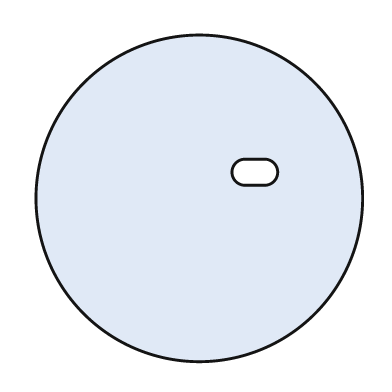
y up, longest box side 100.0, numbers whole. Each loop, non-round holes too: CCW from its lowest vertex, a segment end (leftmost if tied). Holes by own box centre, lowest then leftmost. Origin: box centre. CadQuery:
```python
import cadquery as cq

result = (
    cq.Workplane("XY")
    .moveTo(0.0, 0.0)
    .circle(50.0)
    .moveTo(14.0, 4.0)
    .lineTo(20.0, 4.0)
    .threePointArc((24.0, 8.0), (20.0, 12.0))
    .lineTo(14.0, 12.0)
    .threePointArc((10.0, 8.0), (14.0, 4.0))
    .close()
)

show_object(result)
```